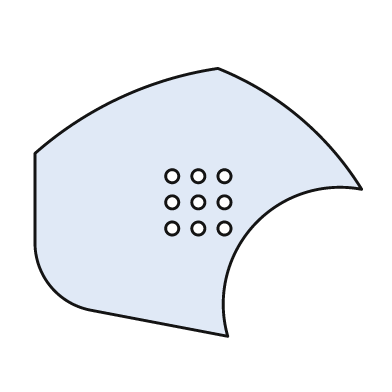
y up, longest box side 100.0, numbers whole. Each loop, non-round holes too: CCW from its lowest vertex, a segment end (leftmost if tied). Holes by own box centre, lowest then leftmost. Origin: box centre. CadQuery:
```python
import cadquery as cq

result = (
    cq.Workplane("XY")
    .moveTo(9.0, -41.0)
    .threePointArc((17.0, -7.0), (50.0, 4.0))
    .threePointArc((31.0, 26.0), (6.0, 41.0))
    .threePointArc((-24.0, 32.0), (-50.0, 15.0))
    .lineTo(-50.0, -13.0)
    .threePointArc((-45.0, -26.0), (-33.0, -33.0))
    .close()
    .moveTo(-8.0, -8.0)
    .circle(2.0)
    .moveTo(0.0, -8.0)
    .circle(2.0)
    .moveTo(8.0, -8.0)
    .circle(2.0)
    .moveTo(-8.0, 0.0)
    .circle(2.0)
    .moveTo(0.0, 0.0)
    .circle(2.0)
    .moveTo(8.0, 0.0)
    .circle(2.0)
    .moveTo(-8.0, 8.0)
    .circle(2.0)
    .moveTo(0.0, 8.0)
    .circle(2.0)
    .moveTo(8.0, 8.0)
    .circle(2.0)
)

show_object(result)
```